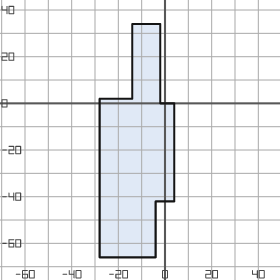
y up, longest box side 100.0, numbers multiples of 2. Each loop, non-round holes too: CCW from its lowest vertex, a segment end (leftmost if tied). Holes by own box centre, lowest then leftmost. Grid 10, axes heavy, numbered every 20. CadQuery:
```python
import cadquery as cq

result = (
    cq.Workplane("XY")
    .moveTo(-28.0, -66.0)
    .lineTo(-4.0, -66.0)
    .lineTo(-4.0, -42.0)
    .lineTo(4.0, -42.0)
    .lineTo(4.0, 0.0)
    .lineTo(-2.0, 0.0)
    .lineTo(-2.0, 34.0)
    .lineTo(-14.0, 34.0)
    .lineTo(-14.0, 2.0)
    .lineTo(-28.0, 2.0)
    .close()
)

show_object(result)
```